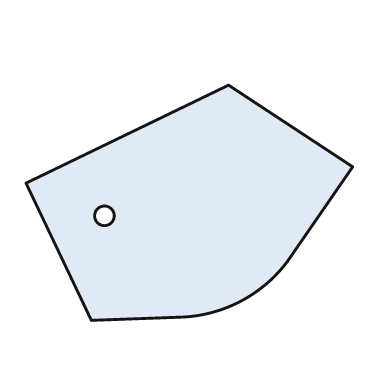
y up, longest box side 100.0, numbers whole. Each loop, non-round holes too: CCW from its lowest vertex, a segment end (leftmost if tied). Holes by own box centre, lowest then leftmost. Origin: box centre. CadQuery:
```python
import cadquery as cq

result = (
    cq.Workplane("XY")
    .moveTo(-30.0, -36.0)
    .lineTo(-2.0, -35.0)
    .threePointArc((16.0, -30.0), (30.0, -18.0))
    .lineTo(50.0, 11.0)
    .lineTo(12.0, 36.0)
    .lineTo(-50.0, 6.0)
    .close()
    .moveTo(-26.0, -4.0)
    .circle(3.0)
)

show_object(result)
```